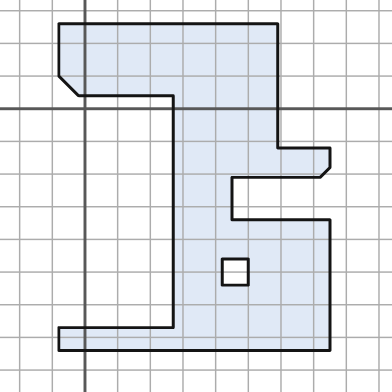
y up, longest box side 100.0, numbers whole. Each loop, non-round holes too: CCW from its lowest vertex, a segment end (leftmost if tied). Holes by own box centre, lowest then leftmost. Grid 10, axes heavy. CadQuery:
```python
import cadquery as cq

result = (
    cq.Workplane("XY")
    .moveTo(-8.0, -74.0)
    .lineTo(75.0, -74.0)
    .lineTo(75.0, -34.0)
    .lineTo(45.0, -34.0)
    .lineTo(45.0, -21.0)
    .lineTo(72.0, -21.0)
    .lineTo(75.0, -18.0)
    .lineTo(75.0, -12.0)
    .lineTo(59.0, -12.0)
    .lineTo(59.0, 26.0)
    .lineTo(-8.0, 26.0)
    .lineTo(-8.0, 10.0)
    .lineTo(-2.0, 4.0)
    .lineTo(27.0, 4.0)
    .lineTo(27.0, -67.0)
    .lineTo(-8.0, -67.0)
    .close()
    .moveTo(42.0, -54.0)
    .lineTo(50.0, -54.0)
    .lineTo(50.0, -46.0)
    .lineTo(42.0, -46.0)
    .close()
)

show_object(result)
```